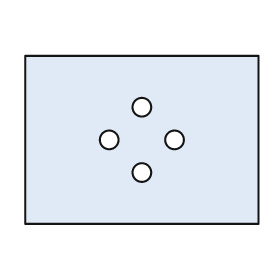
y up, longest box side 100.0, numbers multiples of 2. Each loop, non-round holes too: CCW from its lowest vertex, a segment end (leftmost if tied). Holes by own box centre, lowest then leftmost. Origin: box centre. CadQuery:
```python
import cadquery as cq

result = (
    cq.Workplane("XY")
    .moveTo(-50.0, -36.0)
    .lineTo(50.0, -36.0)
    .lineTo(50.0, 36.0)
    .lineTo(-50.0, 36.0)
    .close()
    .moveTo(0.0, -14.0)
    .circle(4.0)
    .moveTo(-14.0, 0.0)
    .circle(4.0)
    .moveTo(14.0, 0.0)
    .circle(4.0)
    .moveTo(0.0, 14.0)
    .circle(4.0)
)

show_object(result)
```